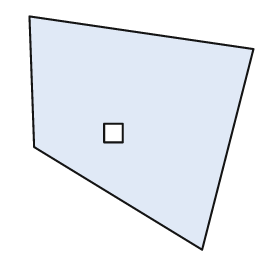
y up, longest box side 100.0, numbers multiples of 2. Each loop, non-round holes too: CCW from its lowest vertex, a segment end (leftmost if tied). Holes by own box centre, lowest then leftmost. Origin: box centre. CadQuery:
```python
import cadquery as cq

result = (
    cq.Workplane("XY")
    .moveTo(26.0, -50.0)
    .lineTo(48.0, 36.0)
    .lineTo(-48.0, 50.0)
    .lineTo(-46.0, -6.0)
    .close()
    .moveTo(-16.0, -4.0)
    .lineTo(-8.0, -4.0)
    .lineTo(-8.0, 4.0)
    .lineTo(-16.0, 4.0)
    .close()
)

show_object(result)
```